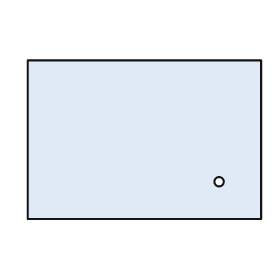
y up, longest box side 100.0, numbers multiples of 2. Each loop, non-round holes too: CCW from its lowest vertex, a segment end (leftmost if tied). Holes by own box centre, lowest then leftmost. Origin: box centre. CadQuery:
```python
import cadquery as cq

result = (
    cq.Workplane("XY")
    .moveTo(-50.0, -34.0)
    .lineTo(50.0, -34.0)
    .lineTo(50.0, 34.0)
    .lineTo(-50.0, 34.0)
    .close()
    .moveTo(32.0, -18.0)
    .circle(2.0)
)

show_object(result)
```